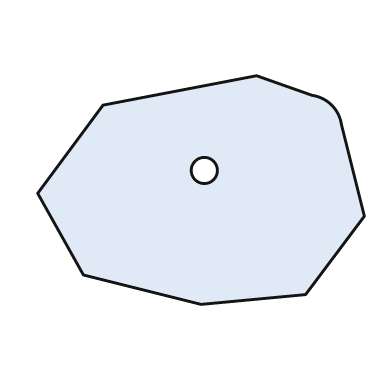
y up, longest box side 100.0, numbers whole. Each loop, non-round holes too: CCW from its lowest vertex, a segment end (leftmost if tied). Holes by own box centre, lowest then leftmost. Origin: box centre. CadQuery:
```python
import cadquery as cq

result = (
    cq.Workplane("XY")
    .moveTo(0.0, -35.0)
    .lineTo(32.0, -32.0)
    .lineTo(50.0, -8.0)
    .lineTo(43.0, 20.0)
    .threePointArc((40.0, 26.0), (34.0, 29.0))
    .lineTo(17.0, 35.0)
    .lineTo(-30.0, 26.0)
    .lineTo(-50.0, -1.0)
    .lineTo(-36.0, -26.0)
    .close()
    .moveTo(1.0, 6.0)
    .circle(4.0)
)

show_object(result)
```